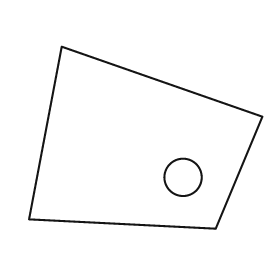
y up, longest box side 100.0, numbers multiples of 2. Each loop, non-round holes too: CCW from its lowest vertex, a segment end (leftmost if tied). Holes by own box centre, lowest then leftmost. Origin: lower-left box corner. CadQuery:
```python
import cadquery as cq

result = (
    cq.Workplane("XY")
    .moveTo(80.0, 0.0)
    .lineTo(100.0, 48.0)
    .lineTo(14.0, 78.0)
    .lineTo(0.0, 4.0)
    .close()
    .moveTo(66.0, 22.0)
    .circle(8.0)
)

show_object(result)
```